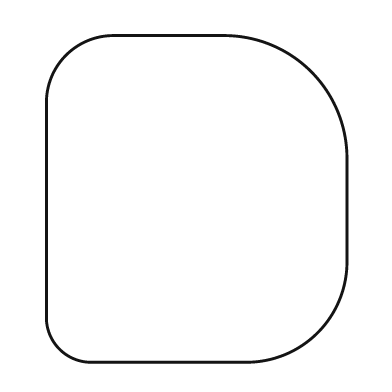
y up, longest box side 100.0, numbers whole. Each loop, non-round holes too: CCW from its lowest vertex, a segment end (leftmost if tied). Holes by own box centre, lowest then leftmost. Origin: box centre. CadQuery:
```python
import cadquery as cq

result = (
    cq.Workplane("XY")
    .moveTo(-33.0, -50.0)
    .lineTo(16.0, -50.0)
    .threePointArc((37.0, -41.0), (46.0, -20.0))
    .lineTo(46.0, 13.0)
    .threePointArc((35.0, 39.0), (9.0, 50.0))
    .lineTo(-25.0, 50.0)
    .threePointArc((-40.0, 44.0), (-46.0, 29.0))
    .lineTo(-46.0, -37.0)
    .threePointArc((-42.0, -46.0), (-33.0, -50.0))
    .close()
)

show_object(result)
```